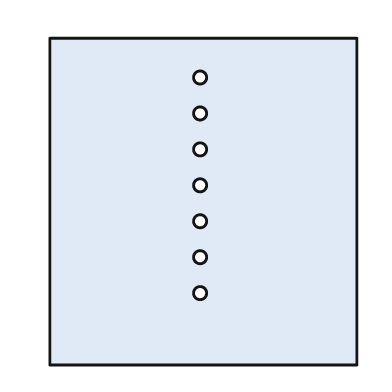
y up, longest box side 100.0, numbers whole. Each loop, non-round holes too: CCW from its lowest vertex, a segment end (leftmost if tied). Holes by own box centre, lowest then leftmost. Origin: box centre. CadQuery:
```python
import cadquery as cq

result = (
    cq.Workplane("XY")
    .moveTo(-47.0, -50.0)
    .lineTo(47.0, -50.0)
    .lineTo(47.0, 50.0)
    .lineTo(-47.0, 50.0)
    .close()
    .moveTo(-1.0, -28.0)
    .circle(2.0)
    .moveTo(-1.0, -17.0)
    .circle(2.0)
    .moveTo(-1.0, -6.0)
    .circle(2.0)
    .moveTo(-1.0, 5.0)
    .circle(2.0)
    .moveTo(-1.0, 16.0)
    .circle(2.0)
    .moveTo(-1.0, 27.0)
    .circle(2.0)
    .moveTo(-1.0, 38.0)
    .circle(2.0)
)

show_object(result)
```